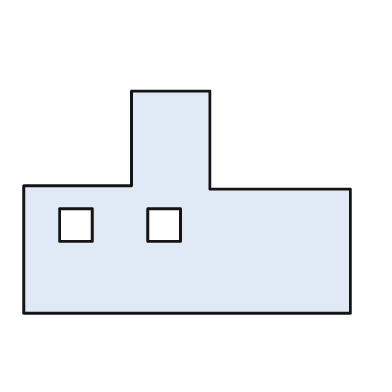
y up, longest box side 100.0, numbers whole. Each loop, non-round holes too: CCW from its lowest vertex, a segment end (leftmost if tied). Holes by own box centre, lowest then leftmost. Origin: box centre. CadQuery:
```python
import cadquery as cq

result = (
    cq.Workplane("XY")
    .moveTo(-50.0, -34.0)
    .lineTo(50.0, -34.0)
    .lineTo(50.0, 4.0)
    .lineTo(7.0, 4.0)
    .lineTo(7.0, 34.0)
    .lineTo(-17.0, 34.0)
    .lineTo(-17.0, 5.0)
    .lineTo(-50.0, 5.0)
    .close()
    .moveTo(-39.0, -12.0)
    .lineTo(-29.0, -12.0)
    .lineTo(-29.0, -2.0)
    .lineTo(-39.0, -2.0)
    .close()
    .moveTo(-12.0, -12.0)
    .lineTo(-2.0, -12.0)
    .lineTo(-2.0, -2.0)
    .lineTo(-12.0, -2.0)
    .close()
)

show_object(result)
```